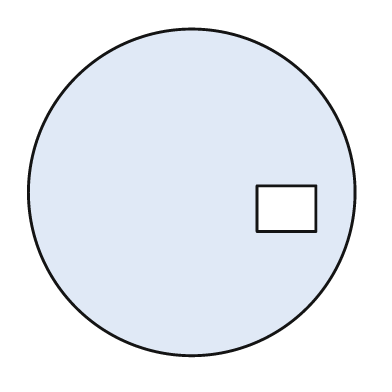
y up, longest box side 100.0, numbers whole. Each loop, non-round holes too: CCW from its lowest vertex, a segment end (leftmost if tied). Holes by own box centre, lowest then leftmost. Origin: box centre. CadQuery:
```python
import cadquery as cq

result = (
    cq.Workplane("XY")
    .moveTo(0.0, 0.0)
    .circle(50.0)
    .moveTo(20.0, -12.0)
    .lineTo(38.0, -12.0)
    .lineTo(38.0, 2.0)
    .lineTo(20.0, 2.0)
    .close()
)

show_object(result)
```